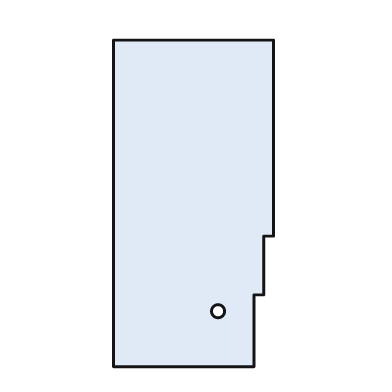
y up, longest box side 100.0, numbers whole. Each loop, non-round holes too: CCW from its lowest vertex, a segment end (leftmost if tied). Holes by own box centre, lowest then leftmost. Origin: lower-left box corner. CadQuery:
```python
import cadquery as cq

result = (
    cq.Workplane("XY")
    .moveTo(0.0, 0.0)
    .lineTo(43.0, 0.0)
    .lineTo(43.0, 22.0)
    .lineTo(46.0, 22.0)
    .lineTo(46.0, 40.0)
    .lineTo(49.0, 40.0)
    .lineTo(49.0, 100.0)
    .lineTo(0.0, 100.0)
    .close()
    .moveTo(32.0, 17.0)
    .circle(2.0)
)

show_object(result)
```